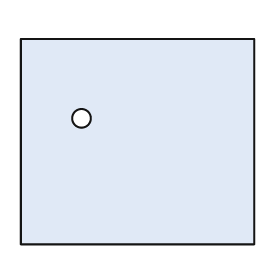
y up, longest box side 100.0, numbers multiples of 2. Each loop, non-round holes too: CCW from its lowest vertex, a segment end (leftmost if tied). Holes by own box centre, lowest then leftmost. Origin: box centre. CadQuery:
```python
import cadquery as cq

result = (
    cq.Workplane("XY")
    .moveTo(-50.0, -44.0)
    .lineTo(50.0, -44.0)
    .lineTo(50.0, 44.0)
    .lineTo(-50.0, 44.0)
    .close()
    .moveTo(-24.0, 10.0)
    .circle(4.0)
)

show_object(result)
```